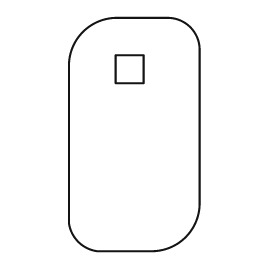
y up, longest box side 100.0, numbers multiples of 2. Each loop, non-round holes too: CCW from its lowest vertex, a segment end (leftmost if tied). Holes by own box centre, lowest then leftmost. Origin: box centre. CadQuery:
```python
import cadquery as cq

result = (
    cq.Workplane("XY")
    .moveTo(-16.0, -50.0)
    .lineTo(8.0, -50.0)
    .threePointArc((22.0, -44.0), (28.0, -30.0))
    .lineTo(28.0, 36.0)
    .threePointArc((24.0, 46.0), (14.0, 50.0))
    .lineTo(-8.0, 50.0)
    .threePointArc((-22.0, 44.0), (-28.0, 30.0))
    .lineTo(-28.0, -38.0)
    .threePointArc((-24.0, -46.0), (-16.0, -50.0))
    .close()
    .moveTo(-8.0, 22.0)
    .lineTo(4.0, 22.0)
    .lineTo(4.0, 34.0)
    .lineTo(-8.0, 34.0)
    .close()
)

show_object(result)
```